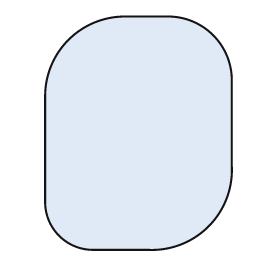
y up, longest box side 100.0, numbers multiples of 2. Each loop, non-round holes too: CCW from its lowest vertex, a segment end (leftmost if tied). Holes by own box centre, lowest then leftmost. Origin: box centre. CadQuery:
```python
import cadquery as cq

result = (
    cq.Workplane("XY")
    .moveTo(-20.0, -50.0)
    .lineTo(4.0, -50.0)
    .threePointArc((30.0, -40.0), (40.0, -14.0))
    .lineTo(40.0, 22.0)
    .threePointArc((32.0, 42.0), (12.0, 50.0))
    .lineTo(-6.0, 50.0)
    .threePointArc((-30.0, 40.0), (-40.0, 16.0))
    .lineTo(-40.0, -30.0)
    .threePointArc((-34.0, -44.0), (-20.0, -50.0))
    .close()
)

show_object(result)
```